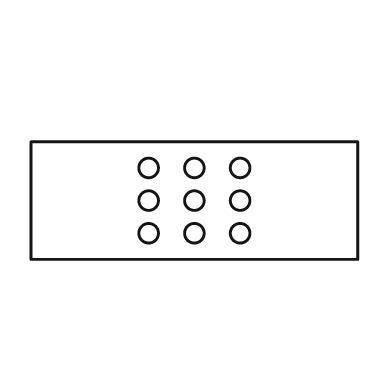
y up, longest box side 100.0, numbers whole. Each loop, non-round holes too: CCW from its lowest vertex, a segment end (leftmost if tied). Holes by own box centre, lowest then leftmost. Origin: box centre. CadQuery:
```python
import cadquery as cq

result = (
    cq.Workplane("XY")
    .moveTo(-50.0, -18.0)
    .lineTo(50.0, -18.0)
    .lineTo(50.0, 18.0)
    .lineTo(-50.0, 18.0)
    .close()
    .moveTo(-14.0, -10.0)
    .circle(3.0)
    .moveTo(0.0, -10.0)
    .circle(3.0)
    .moveTo(14.0, -10.0)
    .circle(3.0)
    .moveTo(-14.0, 0.0)
    .circle(3.0)
    .moveTo(0.0, 0.0)
    .circle(3.0)
    .moveTo(14.0, 0.0)
    .circle(3.0)
    .moveTo(-14.0, 10.0)
    .circle(3.0)
    .moveTo(0.0, 10.0)
    .circle(3.0)
    .moveTo(14.0, 10.0)
    .circle(3.0)
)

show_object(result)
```